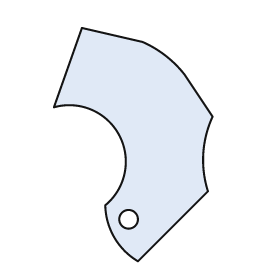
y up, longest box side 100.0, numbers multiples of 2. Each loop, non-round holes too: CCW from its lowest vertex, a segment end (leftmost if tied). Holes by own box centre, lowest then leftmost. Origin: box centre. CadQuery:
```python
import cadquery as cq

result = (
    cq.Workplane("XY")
    .moveTo(2.0, -50.0)
    .lineTo(32.0, -20.0)
    .threePointArc((30.0, -4.0), (34.0, 12.0))
    .lineTo(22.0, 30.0)
    .threePointArc((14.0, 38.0), (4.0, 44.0))
    .lineTo(-22.0, 50.0)
    .lineTo(-34.0, 16.0)
    .threePointArc((-6.0, 4.0), (-12.0, -26.0))
    .threePointArc((-8.0, -40.0), (2.0, -50.0))
    .close()
    .moveTo(-2.0, -32.0)
    .circle(4.0)
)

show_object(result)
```